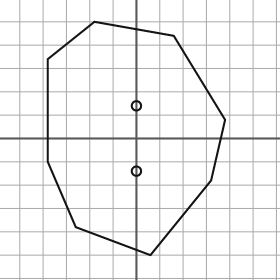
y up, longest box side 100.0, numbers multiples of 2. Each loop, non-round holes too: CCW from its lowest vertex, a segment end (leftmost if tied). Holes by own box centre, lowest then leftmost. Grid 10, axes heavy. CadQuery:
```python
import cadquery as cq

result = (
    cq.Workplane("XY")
    .moveTo(6.0, -50.0)
    .lineTo(32.0, -18.0)
    .lineTo(38.0, 8.0)
    .lineTo(16.0, 44.0)
    .lineTo(-18.0, 50.0)
    .lineTo(-38.0, 34.0)
    .lineTo(-38.0, -10.0)
    .lineTo(-26.0, -38.0)
    .close()
    .moveTo(0.0, -14.0)
    .circle(2.0)
    .moveTo(0.0, 14.0)
    .circle(2.0)
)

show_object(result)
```